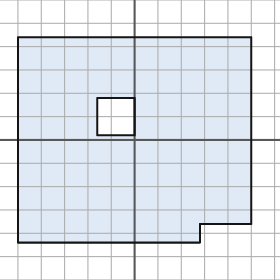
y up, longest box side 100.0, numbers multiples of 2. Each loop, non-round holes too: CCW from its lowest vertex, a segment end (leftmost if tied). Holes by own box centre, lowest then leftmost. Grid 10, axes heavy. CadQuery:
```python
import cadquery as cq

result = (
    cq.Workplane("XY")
    .moveTo(-50.0, -44.0)
    .lineTo(28.0, -44.0)
    .lineTo(28.0, -36.0)
    .lineTo(50.0, -36.0)
    .lineTo(50.0, 44.0)
    .lineTo(-50.0, 44.0)
    .close()
    .moveTo(-16.0, 2.0)
    .lineTo(0.0, 2.0)
    .lineTo(0.0, 18.0)
    .lineTo(-16.0, 18.0)
    .close()
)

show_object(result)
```